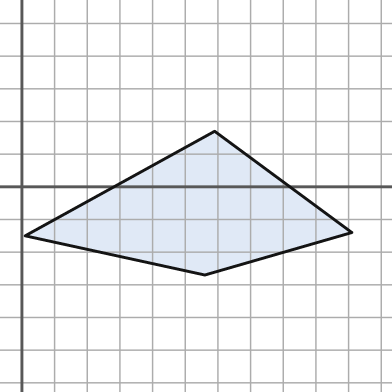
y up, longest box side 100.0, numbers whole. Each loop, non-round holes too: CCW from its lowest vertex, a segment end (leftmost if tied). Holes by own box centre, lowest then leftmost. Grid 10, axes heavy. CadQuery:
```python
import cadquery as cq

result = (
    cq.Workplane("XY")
    .moveTo(56.0, -27.0)
    .lineTo(101.0, -14.0)
    .lineTo(59.0, 17.0)
    .lineTo(1.0, -15.0)
    .close()
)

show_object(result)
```